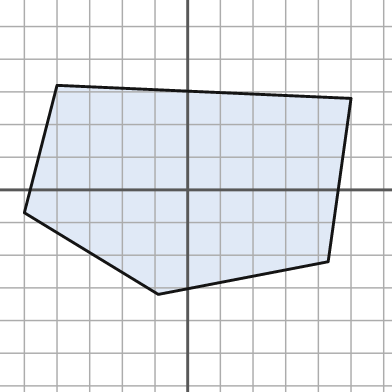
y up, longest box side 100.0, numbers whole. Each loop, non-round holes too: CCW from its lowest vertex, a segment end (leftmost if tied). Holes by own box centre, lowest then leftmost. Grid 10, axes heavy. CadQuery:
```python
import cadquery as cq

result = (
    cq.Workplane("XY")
    .moveTo(-9.0, -32.0)
    .lineTo(43.0, -22.0)
    .lineTo(50.0, 28.0)
    .lineTo(-40.0, 32.0)
    .lineTo(-50.0, -7.0)
    .close()
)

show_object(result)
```